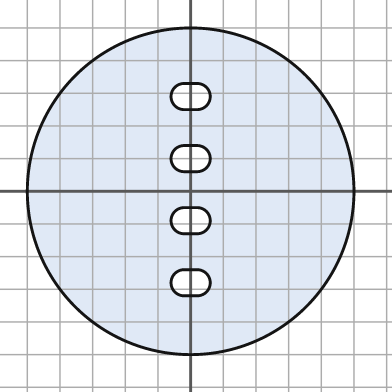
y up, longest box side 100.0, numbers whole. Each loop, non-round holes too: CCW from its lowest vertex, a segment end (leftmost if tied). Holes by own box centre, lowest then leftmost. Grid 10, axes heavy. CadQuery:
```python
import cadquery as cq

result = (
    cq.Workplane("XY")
    .moveTo(0.0, 0.0)
    .circle(50.0)
    .moveTo(-2.0, -32.0)
    .lineTo(2.0, -32.0)
    .threePointArc((6.0, -28.0), (2.0, -24.0))
    .lineTo(-2.0, -24.0)
    .threePointArc((-6.0, -28.0), (-2.0, -32.0))
    .close()
    .moveTo(-2.0, -13.0)
    .lineTo(2.0, -13.0)
    .threePointArc((6.0, -9.0), (2.0, -5.0))
    .lineTo(-2.0, -5.0)
    .threePointArc((-6.0, -9.0), (-2.0, -13.0))
    .close()
    .moveTo(-2.0, 6.0)
    .lineTo(2.0, 6.0)
    .threePointArc((6.0, 10.0), (2.0, 14.0))
    .lineTo(-2.0, 14.0)
    .threePointArc((-6.0, 10.0), (-2.0, 6.0))
    .close()
    .moveTo(-2.0, 25.0)
    .lineTo(2.0, 25.0)
    .threePointArc((6.0, 29.0), (2.0, 33.0))
    .lineTo(-2.0, 33.0)
    .threePointArc((-6.0, 29.0), (-2.0, 25.0))
    .close()
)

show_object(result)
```